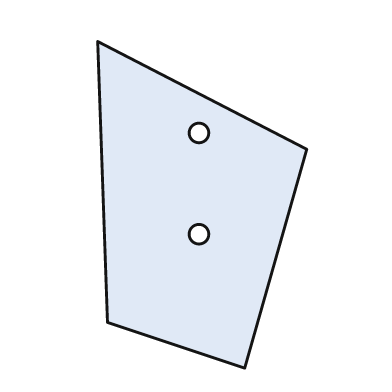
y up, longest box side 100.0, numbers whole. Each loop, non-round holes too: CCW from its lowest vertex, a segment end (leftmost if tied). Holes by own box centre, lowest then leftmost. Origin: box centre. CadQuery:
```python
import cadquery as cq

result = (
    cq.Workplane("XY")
    .moveTo(13.0, -50.0)
    .lineTo(32.0, 17.0)
    .lineTo(-32.0, 50.0)
    .lineTo(-29.0, -36.0)
    .close()
    .moveTo(-1.0, -9.0)
    .circle(3.0)
    .moveTo(-1.0, 22.0)
    .circle(3.0)
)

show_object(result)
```